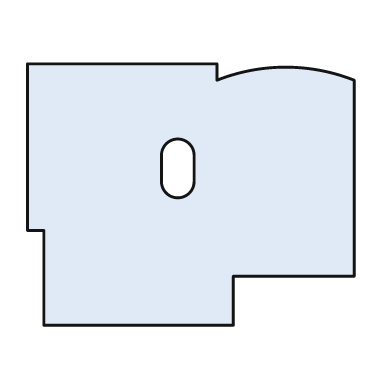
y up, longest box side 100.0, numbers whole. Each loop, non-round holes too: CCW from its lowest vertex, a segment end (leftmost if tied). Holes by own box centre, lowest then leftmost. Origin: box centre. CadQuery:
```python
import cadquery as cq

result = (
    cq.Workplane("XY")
    .moveTo(-45.0, -40.0)
    .lineTo(13.0, -40.0)
    .lineTo(13.0, -25.0)
    .lineTo(50.0, -25.0)
    .lineTo(50.0, 35.0)
    .threePointArc((29.0, 39.0), (8.0, 35.0))
    .lineTo(8.0, 40.0)
    .lineTo(-50.0, 40.0)
    .lineTo(-50.0, -11.0)
    .lineTo(-45.0, -11.0)
    .close()
    .moveTo(-9.0, 4.0)
    .threePointArc((-4.0, -1.0), (1.0, 4.0))
    .lineTo(1.0, 12.0)
    .threePointArc((-4.0, 17.0), (-9.0, 12.0))
    .close()
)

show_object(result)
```